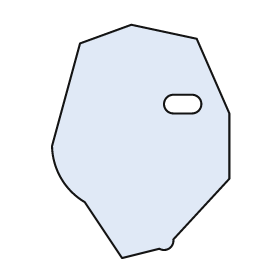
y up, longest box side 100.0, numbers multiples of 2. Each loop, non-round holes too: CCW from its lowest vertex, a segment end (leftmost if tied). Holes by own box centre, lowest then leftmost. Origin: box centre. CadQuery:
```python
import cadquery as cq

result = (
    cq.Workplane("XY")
    .moveTo(-8.0, -50.0)
    .lineTo(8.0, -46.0)
    .threePointArc((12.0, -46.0), (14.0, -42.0))
    .lineTo(38.0, -16.0)
    .lineTo(38.0, 12.0)
    .lineTo(24.0, 44.0)
    .lineTo(-4.0, 50.0)
    .lineTo(-26.0, 42.0)
    .lineTo(-38.0, -2.0)
    .threePointArc((-34.0, -16.0), (-24.0, -26.0))
    .close()
    .moveTo(14.0, 12.0)
    .lineTo(22.0, 12.0)
    .threePointArc((26.0, 16.0), (22.0, 20.0))
    .lineTo(14.0, 20.0)
    .threePointArc((10.0, 16.0), (14.0, 12.0))
    .close()
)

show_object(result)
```